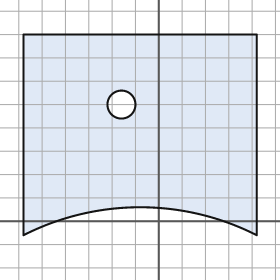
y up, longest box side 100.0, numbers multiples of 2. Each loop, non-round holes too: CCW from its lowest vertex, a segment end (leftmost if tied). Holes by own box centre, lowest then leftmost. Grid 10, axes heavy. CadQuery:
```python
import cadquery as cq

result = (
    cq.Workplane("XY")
    .moveTo(-58.0, -6.0)
    .threePointArc((-8.0, 6.0), (42.0, -6.0))
    .lineTo(42.0, 80.0)
    .lineTo(-58.0, 80.0)
    .close()
    .moveTo(-16.0, 50.0)
    .circle(6.0)
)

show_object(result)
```